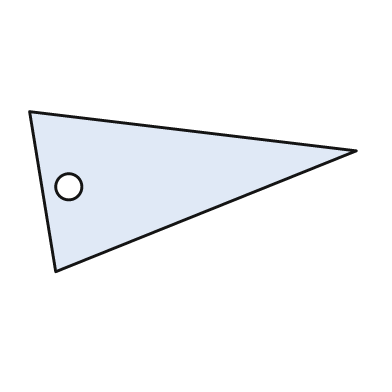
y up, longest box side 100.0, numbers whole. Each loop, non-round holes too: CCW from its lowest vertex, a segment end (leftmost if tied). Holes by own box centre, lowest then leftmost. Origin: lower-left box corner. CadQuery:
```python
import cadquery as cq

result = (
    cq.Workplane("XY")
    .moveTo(8.0, 0.0)
    .lineTo(100.0, 37.0)
    .lineTo(0.0, 49.0)
    .close()
    .moveTo(12.0, 26.0)
    .circle(4.0)
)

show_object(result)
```